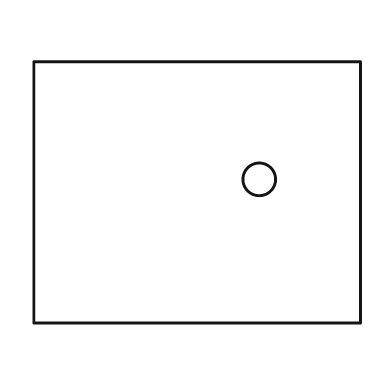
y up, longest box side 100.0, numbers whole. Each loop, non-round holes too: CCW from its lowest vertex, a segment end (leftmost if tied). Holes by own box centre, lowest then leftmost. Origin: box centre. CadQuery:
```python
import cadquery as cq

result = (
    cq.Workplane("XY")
    .moveTo(-50.0, -40.0)
    .lineTo(50.0, -40.0)
    .lineTo(50.0, 40.0)
    .lineTo(-50.0, 40.0)
    .close()
    .moveTo(19.0, 4.0)
    .circle(5.0)
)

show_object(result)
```